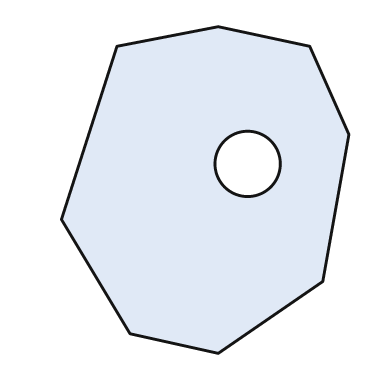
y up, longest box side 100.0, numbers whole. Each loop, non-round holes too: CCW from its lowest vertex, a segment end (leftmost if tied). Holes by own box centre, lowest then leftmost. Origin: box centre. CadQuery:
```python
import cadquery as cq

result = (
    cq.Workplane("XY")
    .moveTo(4.0, -50.0)
    .lineTo(36.0, -28.0)
    .lineTo(44.0, 17.0)
    .lineTo(32.0, 44.0)
    .lineTo(4.0, 50.0)
    .lineTo(-27.0, 44.0)
    .lineTo(-44.0, -9.0)
    .lineTo(-23.0, -44.0)
    .close()
    .moveTo(13.0, 8.0)
    .circle(10.0)
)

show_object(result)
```